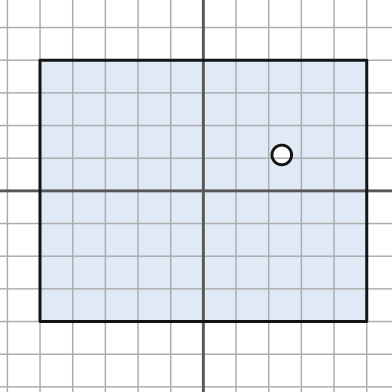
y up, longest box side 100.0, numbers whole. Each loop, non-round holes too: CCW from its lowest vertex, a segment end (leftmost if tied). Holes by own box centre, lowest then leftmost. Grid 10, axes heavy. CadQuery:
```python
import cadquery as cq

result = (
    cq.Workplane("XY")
    .moveTo(-50.0, -40.0)
    .lineTo(50.0, -40.0)
    .lineTo(50.0, 40.0)
    .lineTo(-50.0, 40.0)
    .close()
    .moveTo(24.0, 11.0)
    .circle(3.0)
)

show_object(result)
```